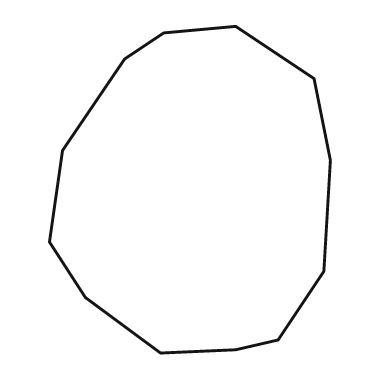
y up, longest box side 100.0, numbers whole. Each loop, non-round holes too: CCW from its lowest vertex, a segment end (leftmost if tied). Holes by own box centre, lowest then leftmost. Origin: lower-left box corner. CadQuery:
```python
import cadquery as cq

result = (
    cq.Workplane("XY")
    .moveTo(34.0, 0.0)
    .lineTo(57.0, 1.0)
    .lineTo(70.0, 4.0)
    .lineTo(84.0, 25.0)
    .lineTo(86.0, 59.0)
    .lineTo(81.0, 84.0)
    .lineTo(57.0, 100.0)
    .lineTo(35.0, 98.0)
    .lineTo(23.0, 90.0)
    .lineTo(4.0, 62.0)
    .lineTo(0.0, 34.0)
    .lineTo(11.0, 17.0)
    .close()
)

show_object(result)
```